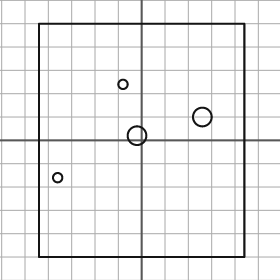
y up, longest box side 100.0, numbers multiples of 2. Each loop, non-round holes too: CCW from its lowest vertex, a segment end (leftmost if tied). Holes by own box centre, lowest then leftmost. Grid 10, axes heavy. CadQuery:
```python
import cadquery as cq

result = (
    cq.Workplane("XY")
    .moveTo(-44.0, -50.0)
    .lineTo(44.0, -50.0)
    .lineTo(44.0, 50.0)
    .lineTo(-44.0, 50.0)
    .close()
    .moveTo(-36.0, -16.0)
    .circle(2.0)
    .moveTo(-2.0, 2.0)
    .circle(4.0)
    .moveTo(26.0, 10.0)
    .circle(4.0)
    .moveTo(-8.0, 24.0)
    .circle(2.0)
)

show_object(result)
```